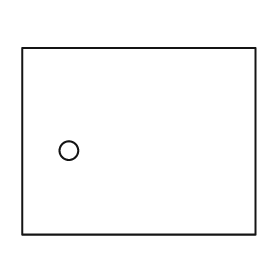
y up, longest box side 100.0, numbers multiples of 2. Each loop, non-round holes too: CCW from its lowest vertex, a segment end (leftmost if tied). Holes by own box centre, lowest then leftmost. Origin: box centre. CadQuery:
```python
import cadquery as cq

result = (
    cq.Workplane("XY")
    .moveTo(-50.0, -40.0)
    .lineTo(50.0, -40.0)
    .lineTo(50.0, 40.0)
    .lineTo(-50.0, 40.0)
    .close()
    .moveTo(-30.0, -4.0)
    .circle(4.0)
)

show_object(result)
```